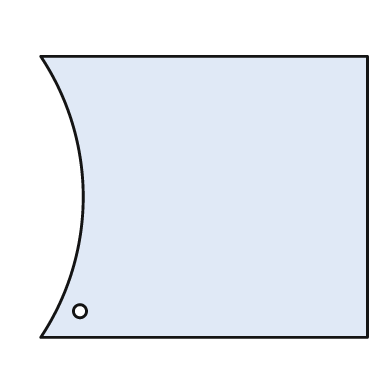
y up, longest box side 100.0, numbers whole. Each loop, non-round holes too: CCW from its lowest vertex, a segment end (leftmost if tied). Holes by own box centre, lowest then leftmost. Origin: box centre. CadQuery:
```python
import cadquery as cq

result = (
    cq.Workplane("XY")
    .moveTo(-50.0, -43.0)
    .lineTo(50.0, -43.0)
    .lineTo(50.0, 43.0)
    .lineTo(-50.0, 43.0)
    .threePointArc((-37.0, 0.0), (-50.0, -43.0))
    .close()
    .moveTo(-38.0, -35.0)
    .circle(2.0)
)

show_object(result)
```